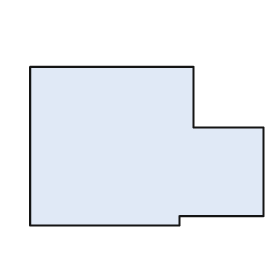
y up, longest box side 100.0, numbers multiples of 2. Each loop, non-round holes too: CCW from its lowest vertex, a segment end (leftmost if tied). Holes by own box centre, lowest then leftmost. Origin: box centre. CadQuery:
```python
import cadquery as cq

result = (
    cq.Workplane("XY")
    .moveTo(-50.0, -34.0)
    .lineTo(14.0, -34.0)
    .lineTo(14.0, -30.0)
    .lineTo(50.0, -30.0)
    .lineTo(50.0, 8.0)
    .lineTo(20.0, 8.0)
    .lineTo(20.0, 34.0)
    .lineTo(-50.0, 34.0)
    .close()
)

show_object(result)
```